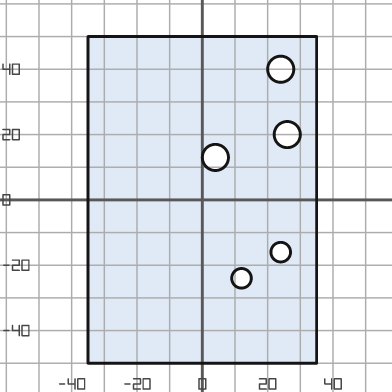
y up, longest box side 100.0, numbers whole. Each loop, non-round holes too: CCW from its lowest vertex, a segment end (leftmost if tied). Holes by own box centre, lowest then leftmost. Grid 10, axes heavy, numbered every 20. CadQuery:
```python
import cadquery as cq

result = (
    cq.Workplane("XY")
    .moveTo(-35.0, -50.0)
    .lineTo(35.0, -50.0)
    .lineTo(35.0, 50.0)
    .lineTo(-35.0, 50.0)
    .close()
    .moveTo(12.0, -24.0)
    .circle(3.0)
    .moveTo(24.0, -16.0)
    .circle(3.0)
    .moveTo(4.0, 13.0)
    .circle(4.0)
    .moveTo(26.0, 20.0)
    .circle(4.0)
    .moveTo(24.0, 40.0)
    .circle(4.0)
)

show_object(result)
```